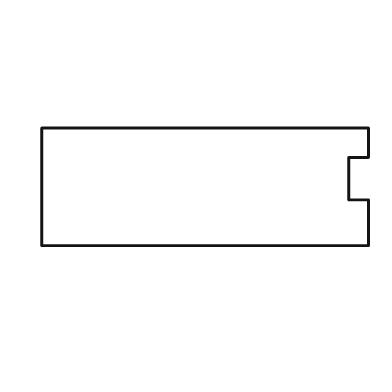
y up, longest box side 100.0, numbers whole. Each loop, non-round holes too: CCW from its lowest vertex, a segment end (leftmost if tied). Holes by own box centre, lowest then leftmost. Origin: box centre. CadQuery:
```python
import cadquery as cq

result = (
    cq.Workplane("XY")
    .moveTo(-50.0, -18.0)
    .lineTo(50.0, -18.0)
    .lineTo(50.0, -4.0)
    .lineTo(44.0, -4.0)
    .lineTo(44.0, 9.0)
    .lineTo(50.0, 9.0)
    .lineTo(50.0, 18.0)
    .lineTo(-50.0, 18.0)
    .close()
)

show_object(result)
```